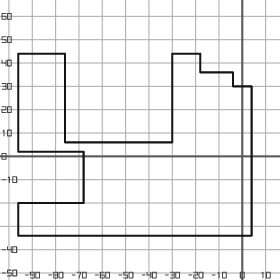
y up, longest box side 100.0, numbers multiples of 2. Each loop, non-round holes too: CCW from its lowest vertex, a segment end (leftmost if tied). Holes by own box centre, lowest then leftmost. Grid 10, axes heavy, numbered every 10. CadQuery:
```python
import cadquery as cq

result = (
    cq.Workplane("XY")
    .moveTo(-96.0, -34.0)
    .lineTo(4.0, -34.0)
    .lineTo(4.0, 30.0)
    .lineTo(-4.0, 30.0)
    .lineTo(-4.0, 36.0)
    .lineTo(-18.0, 36.0)
    .lineTo(-18.0, 44.0)
    .lineTo(-30.0, 44.0)
    .lineTo(-30.0, 6.0)
    .lineTo(-76.0, 6.0)
    .lineTo(-76.0, 44.0)
    .lineTo(-96.0, 44.0)
    .lineTo(-96.0, 2.0)
    .lineTo(-68.0, 2.0)
    .lineTo(-68.0, -20.0)
    .lineTo(-96.0, -20.0)
    .close()
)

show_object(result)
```